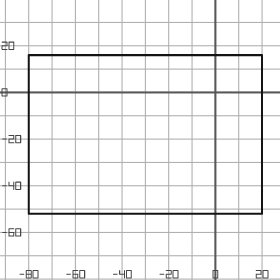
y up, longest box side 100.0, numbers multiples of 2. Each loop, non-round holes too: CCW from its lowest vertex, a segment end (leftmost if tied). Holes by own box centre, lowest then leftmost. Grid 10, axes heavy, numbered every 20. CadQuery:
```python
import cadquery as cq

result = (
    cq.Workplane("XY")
    .moveTo(-80.0, -52.0)
    .lineTo(20.0, -52.0)
    .lineTo(20.0, 16.0)
    .lineTo(-80.0, 16.0)
    .close()
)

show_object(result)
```